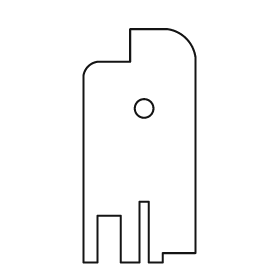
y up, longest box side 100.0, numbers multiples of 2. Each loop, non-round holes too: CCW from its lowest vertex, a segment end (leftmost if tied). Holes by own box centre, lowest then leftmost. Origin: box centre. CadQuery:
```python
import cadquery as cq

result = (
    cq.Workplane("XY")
    .moveTo(-24.0, -50.0)
    .lineTo(-18.0, -50.0)
    .lineTo(-18.0, -30.0)
    .lineTo(-8.0, -30.0)
    .lineTo(-8.0, -50.0)
    .lineTo(0.0, -50.0)
    .lineTo(0.0, -24.0)
    .lineTo(4.0, -24.0)
    .lineTo(4.0, -50.0)
    .lineTo(10.0, -50.0)
    .lineTo(10.0, -46.0)
    .lineTo(24.0, -46.0)
    .lineTo(24.0, 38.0)
    .threePointArc((20.0, 46.0), (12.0, 50.0))
    .lineTo(-4.0, 50.0)
    .lineTo(-4.0, 36.0)
    .lineTo(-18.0, 36.0)
    .threePointArc((-22.0, 34.0), (-24.0, 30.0))
    .close()
    .moveTo(2.0, 16.0)
    .circle(4.0)
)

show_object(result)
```